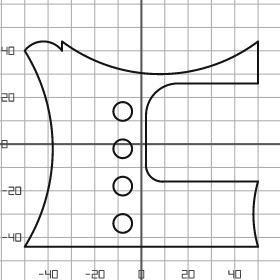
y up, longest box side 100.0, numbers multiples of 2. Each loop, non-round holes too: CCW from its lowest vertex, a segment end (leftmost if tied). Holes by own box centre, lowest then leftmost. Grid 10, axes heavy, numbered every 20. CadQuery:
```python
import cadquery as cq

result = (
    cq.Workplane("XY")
    .moveTo(-50.0, -44.0)
    .lineTo(50.0, -44.0)
    .threePointArc((48.0, -30.0), (50.0, -16.0))
    .lineTo(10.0, -16.0)
    .threePointArc((4.0, -14.0), (2.0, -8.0))
    .lineTo(2.0, 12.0)
    .threePointArc((6.0, 22.0), (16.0, 26.0))
    .lineTo(50.0, 26.0)
    .lineTo(50.0, 44.0)
    .threePointArc((8.0, 30.0), (-34.0, 44.0))
    .lineTo(-34.0, 40.0)
    .threePointArc((-42.0, 44.0), (-50.0, 40.0))
    .threePointArc((-38.0, -2.0), (-50.0, -44.0))
    .close()
    .moveTo(-8.0, -34.0)
    .circle(4.0)
    .moveTo(-8.0, -18.0)
    .circle(4.0)
    .moveTo(-8.0, -2.0)
    .circle(4.0)
    .moveTo(-8.0, 14.0)
    .circle(4.0)
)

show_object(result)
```